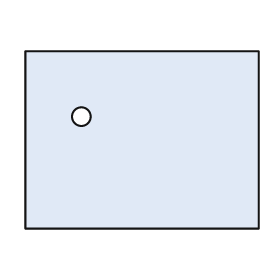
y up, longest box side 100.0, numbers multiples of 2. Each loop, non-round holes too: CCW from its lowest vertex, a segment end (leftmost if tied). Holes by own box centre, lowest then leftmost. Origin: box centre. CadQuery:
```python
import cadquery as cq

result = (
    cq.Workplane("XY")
    .moveTo(-50.0, -38.0)
    .lineTo(50.0, -38.0)
    .lineTo(50.0, 38.0)
    .lineTo(-50.0, 38.0)
    .close()
    .moveTo(-26.0, 10.0)
    .circle(4.0)
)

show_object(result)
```